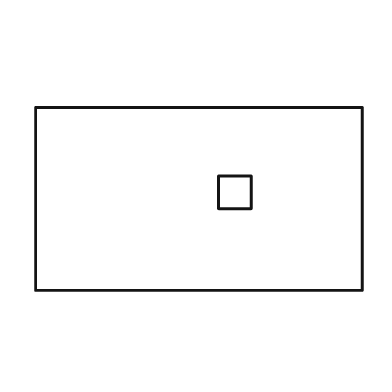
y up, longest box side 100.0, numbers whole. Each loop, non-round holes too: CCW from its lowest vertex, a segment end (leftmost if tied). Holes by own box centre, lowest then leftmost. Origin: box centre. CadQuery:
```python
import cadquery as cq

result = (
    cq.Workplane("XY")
    .moveTo(-50.0, -28.0)
    .lineTo(50.0, -28.0)
    .lineTo(50.0, 28.0)
    .lineTo(-50.0, 28.0)
    .close()
    .moveTo(6.0, -3.0)
    .lineTo(16.0, -3.0)
    .lineTo(16.0, 7.0)
    .lineTo(6.0, 7.0)
    .close()
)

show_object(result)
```